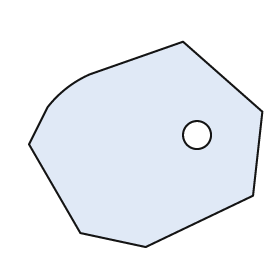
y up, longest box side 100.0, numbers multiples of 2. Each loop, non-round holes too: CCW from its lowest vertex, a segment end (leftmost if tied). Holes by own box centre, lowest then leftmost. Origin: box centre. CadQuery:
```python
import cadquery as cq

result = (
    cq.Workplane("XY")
    .moveTo(0.0, -44.0)
    .lineTo(46.0, -22.0)
    .lineTo(50.0, 14.0)
    .lineTo(16.0, 44.0)
    .lineTo(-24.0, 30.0)
    .threePointArc((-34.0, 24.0), (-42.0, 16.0))
    .lineTo(-50.0, 0.0)
    .lineTo(-28.0, -38.0)
    .close()
    .moveTo(22.0, 4.0)
    .circle(6.0)
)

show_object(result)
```